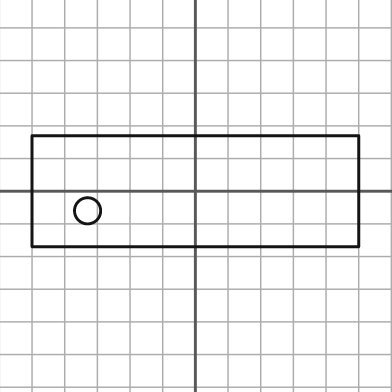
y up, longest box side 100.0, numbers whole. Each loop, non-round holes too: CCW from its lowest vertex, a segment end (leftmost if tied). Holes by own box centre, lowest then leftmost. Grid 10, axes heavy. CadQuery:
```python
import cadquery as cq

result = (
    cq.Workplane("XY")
    .moveTo(-50.0, -17.0)
    .lineTo(50.0, -17.0)
    .lineTo(50.0, 17.0)
    .lineTo(-50.0, 17.0)
    .close()
    .moveTo(-33.0, -6.0)
    .circle(4.0)
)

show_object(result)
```